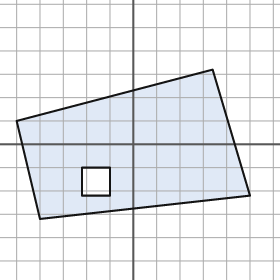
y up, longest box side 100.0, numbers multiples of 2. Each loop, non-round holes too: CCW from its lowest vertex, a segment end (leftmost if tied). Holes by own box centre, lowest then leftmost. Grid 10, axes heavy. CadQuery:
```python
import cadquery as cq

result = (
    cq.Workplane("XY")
    .moveTo(-40.0, -32.0)
    .lineTo(50.0, -22.0)
    .lineTo(34.0, 32.0)
    .lineTo(-50.0, 10.0)
    .close()
    .moveTo(-22.0, -22.0)
    .lineTo(-10.0, -22.0)
    .lineTo(-10.0, -10.0)
    .lineTo(-22.0, -10.0)
    .close()
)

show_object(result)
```